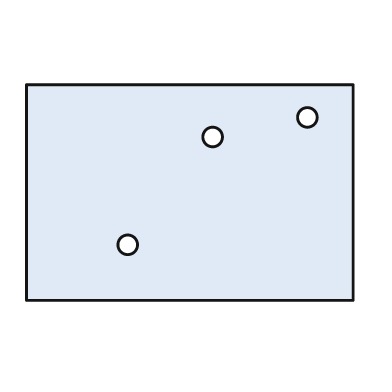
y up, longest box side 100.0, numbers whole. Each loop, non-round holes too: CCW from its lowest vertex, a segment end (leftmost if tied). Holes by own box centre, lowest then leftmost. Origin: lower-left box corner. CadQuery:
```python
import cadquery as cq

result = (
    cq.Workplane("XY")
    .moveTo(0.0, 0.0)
    .lineTo(100.0, 0.0)
    .lineTo(100.0, 66.0)
    .lineTo(0.0, 66.0)
    .close()
    .moveTo(31.0, 17.0)
    .circle(3.0)
    .moveTo(57.0, 50.0)
    .circle(3.0)
    .moveTo(86.0, 56.0)
    .circle(3.0)
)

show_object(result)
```